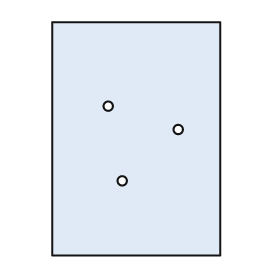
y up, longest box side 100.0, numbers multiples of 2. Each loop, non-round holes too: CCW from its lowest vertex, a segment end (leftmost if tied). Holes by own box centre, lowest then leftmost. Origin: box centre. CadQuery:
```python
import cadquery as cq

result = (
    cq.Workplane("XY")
    .moveTo(-36.0, -50.0)
    .lineTo(36.0, -50.0)
    .lineTo(36.0, 50.0)
    .lineTo(-36.0, 50.0)
    .close()
    .moveTo(-6.0, -18.0)
    .circle(2.0)
    .moveTo(18.0, 4.0)
    .circle(2.0)
    .moveTo(-12.0, 14.0)
    .circle(2.0)
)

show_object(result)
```